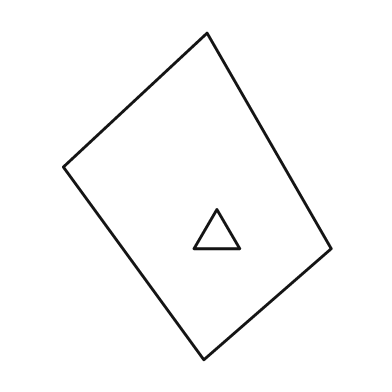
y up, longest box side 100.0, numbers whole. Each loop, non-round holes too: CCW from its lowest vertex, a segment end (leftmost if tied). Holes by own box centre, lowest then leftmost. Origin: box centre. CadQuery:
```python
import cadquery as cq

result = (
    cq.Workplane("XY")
    .moveTo(2.0, -50.0)
    .lineTo(41.0, -16.0)
    .lineTo(3.0, 50.0)
    .lineTo(-41.0, 9.0)
    .close()
    .moveTo(-1.0, -16.0)
    .lineTo(13.0, -16.0)
    .lineTo(6.0, -4.0)
    .close()
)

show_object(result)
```